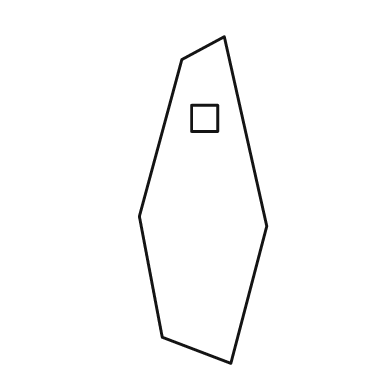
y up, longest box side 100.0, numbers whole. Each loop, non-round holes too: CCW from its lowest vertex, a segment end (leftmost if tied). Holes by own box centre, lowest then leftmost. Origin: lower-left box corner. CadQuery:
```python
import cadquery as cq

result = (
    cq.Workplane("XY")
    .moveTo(28.0, 0.0)
    .lineTo(39.0, 42.0)
    .lineTo(26.0, 100.0)
    .lineTo(13.0, 93.0)
    .lineTo(0.0, 45.0)
    .lineTo(7.0, 8.0)
    .close()
    .moveTo(16.0, 71.0)
    .lineTo(24.0, 71.0)
    .lineTo(24.0, 79.0)
    .lineTo(16.0, 79.0)
    .close()
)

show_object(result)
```